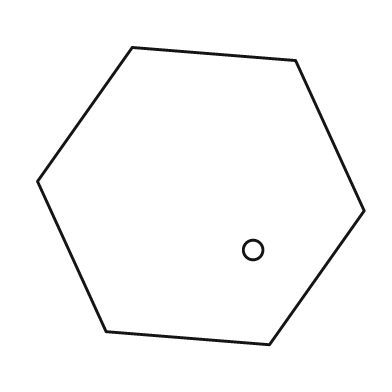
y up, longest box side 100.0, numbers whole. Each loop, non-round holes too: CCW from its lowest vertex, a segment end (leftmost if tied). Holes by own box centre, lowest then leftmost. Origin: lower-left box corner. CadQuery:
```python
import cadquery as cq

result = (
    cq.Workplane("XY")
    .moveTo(71.0, 0.0)
    .lineTo(100.0, 41.0)
    .lineTo(79.0, 87.0)
    .lineTo(29.0, 91.0)
    .lineTo(0.0, 50.0)
    .lineTo(21.0, 4.0)
    .close()
    .moveTo(66.0, 29.0)
    .circle(3.0)
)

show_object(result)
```